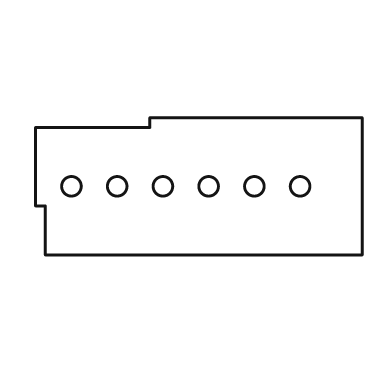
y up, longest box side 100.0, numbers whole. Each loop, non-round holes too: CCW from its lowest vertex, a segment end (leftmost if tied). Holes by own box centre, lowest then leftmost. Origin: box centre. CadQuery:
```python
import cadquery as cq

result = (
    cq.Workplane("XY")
    .moveTo(-47.0, -21.0)
    .lineTo(50.0, -21.0)
    .lineTo(50.0, 21.0)
    .lineTo(-15.0, 21.0)
    .lineTo(-15.0, 18.0)
    .lineTo(-50.0, 18.0)
    .lineTo(-50.0, -6.0)
    .lineTo(-47.0, -6.0)
    .close()
    .moveTo(-39.0, 0.0)
    .circle(3.0)
    .moveTo(-25.0, 0.0)
    .circle(3.0)
    .moveTo(-11.0, 0.0)
    .circle(3.0)
    .moveTo(3.0, 0.0)
    .circle(3.0)
    .moveTo(17.0, 0.0)
    .circle(3.0)
    .moveTo(31.0, 0.0)
    .circle(3.0)
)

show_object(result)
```